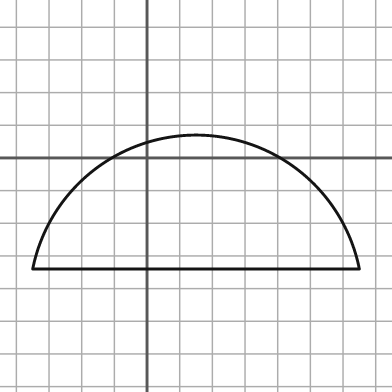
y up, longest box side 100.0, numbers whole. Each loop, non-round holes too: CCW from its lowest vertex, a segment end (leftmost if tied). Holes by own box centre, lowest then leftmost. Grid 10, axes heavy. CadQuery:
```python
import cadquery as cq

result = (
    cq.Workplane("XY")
    .moveTo(-35.0, -34.0)
    .lineTo(65.0, -34.0)
    .threePointArc((15.0, 7.0), (-35.0, -34.0))
    .close()
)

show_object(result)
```